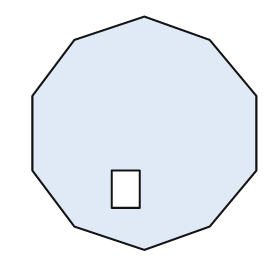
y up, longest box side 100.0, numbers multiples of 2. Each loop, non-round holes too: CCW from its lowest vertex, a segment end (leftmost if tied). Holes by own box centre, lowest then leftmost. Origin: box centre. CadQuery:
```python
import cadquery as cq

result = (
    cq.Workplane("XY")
    .moveTo(0.0, -50.0)
    .lineTo(28.0, -40.0)
    .lineTo(48.0, -16.0)
    .lineTo(48.0, 16.0)
    .lineTo(28.0, 40.0)
    .lineTo(0.0, 50.0)
    .lineTo(-30.0, 40.0)
    .lineTo(-48.0, 16.0)
    .lineTo(-48.0, -16.0)
    .lineTo(-30.0, -40.0)
    .close()
    .moveTo(-14.0, -32.0)
    .lineTo(-2.0, -32.0)
    .lineTo(-2.0, -16.0)
    .lineTo(-14.0, -16.0)
    .close()
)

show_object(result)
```